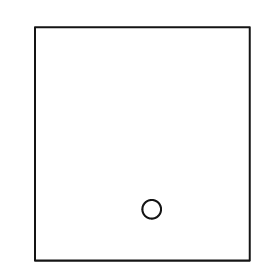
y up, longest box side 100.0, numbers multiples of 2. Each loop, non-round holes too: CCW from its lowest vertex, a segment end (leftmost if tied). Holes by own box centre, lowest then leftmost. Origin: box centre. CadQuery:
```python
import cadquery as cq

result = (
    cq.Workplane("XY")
    .moveTo(-46.0, -50.0)
    .lineTo(46.0, -50.0)
    .lineTo(46.0, 50.0)
    .lineTo(-46.0, 50.0)
    .close()
    .moveTo(4.0, -28.0)
    .circle(4.0)
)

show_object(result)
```